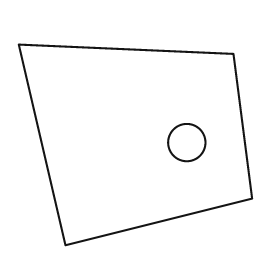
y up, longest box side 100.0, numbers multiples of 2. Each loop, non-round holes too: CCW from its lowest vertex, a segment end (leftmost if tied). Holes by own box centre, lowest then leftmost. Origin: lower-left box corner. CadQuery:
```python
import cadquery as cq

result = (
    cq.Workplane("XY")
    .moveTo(20.0, 0.0)
    .lineTo(100.0, 20.0)
    .lineTo(92.0, 82.0)
    .lineTo(0.0, 86.0)
    .close()
    .moveTo(72.0, 44.0)
    .circle(8.0)
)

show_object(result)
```